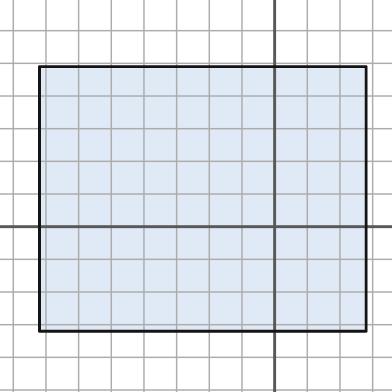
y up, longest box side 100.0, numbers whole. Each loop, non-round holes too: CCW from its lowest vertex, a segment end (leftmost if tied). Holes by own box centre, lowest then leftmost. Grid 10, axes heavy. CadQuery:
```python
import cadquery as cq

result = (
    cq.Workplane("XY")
    .moveTo(-72.0, -32.0)
    .lineTo(28.0, -32.0)
    .lineTo(28.0, 49.0)
    .lineTo(-72.0, 49.0)
    .close()
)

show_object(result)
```